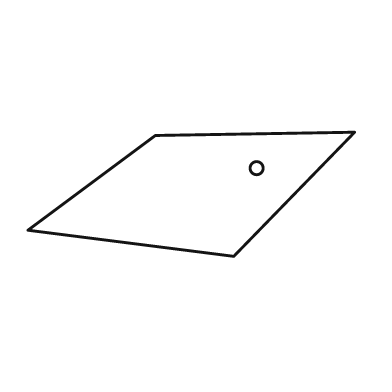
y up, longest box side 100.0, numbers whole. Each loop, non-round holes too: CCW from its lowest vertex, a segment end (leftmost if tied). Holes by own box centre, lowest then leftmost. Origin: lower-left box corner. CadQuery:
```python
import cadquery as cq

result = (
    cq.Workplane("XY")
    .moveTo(63.0, 0.0)
    .lineTo(100.0, 38.0)
    .lineTo(39.0, 37.0)
    .lineTo(0.0, 8.0)
    .close()
    .moveTo(70.0, 27.0)
    .circle(2.0)
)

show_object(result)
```